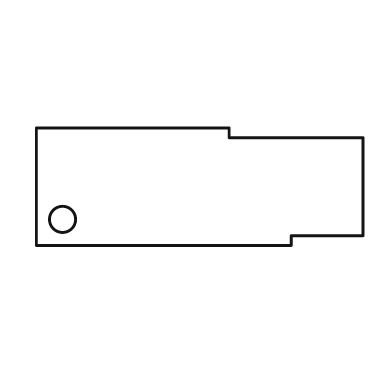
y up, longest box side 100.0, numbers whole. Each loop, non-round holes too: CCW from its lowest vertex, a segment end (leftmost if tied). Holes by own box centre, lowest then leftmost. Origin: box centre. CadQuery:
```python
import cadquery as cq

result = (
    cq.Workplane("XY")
    .moveTo(-50.0, -18.0)
    .lineTo(28.0, -18.0)
    .lineTo(28.0, -15.0)
    .lineTo(50.0, -15.0)
    .lineTo(50.0, 15.0)
    .lineTo(9.0, 15.0)
    .lineTo(9.0, 18.0)
    .lineTo(-50.0, 18.0)
    .close()
    .moveTo(-42.0, -10.0)
    .circle(4.0)
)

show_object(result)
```